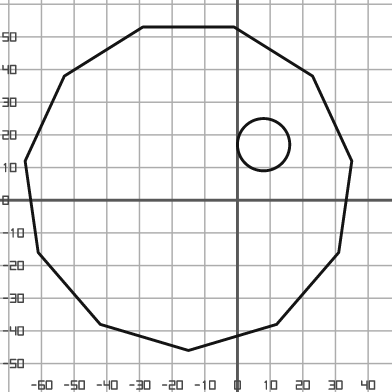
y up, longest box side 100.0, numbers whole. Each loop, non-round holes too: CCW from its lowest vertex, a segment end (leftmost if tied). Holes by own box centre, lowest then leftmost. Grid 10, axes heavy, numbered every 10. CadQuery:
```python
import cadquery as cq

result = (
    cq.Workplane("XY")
    .moveTo(-15.0, -46.0)
    .lineTo(12.0, -38.0)
    .lineTo(31.0, -16.0)
    .lineTo(35.0, 12.0)
    .lineTo(23.0, 38.0)
    .lineTo(-1.0, 53.0)
    .lineTo(-29.0, 53.0)
    .lineTo(-53.0, 38.0)
    .lineTo(-65.0, 12.0)
    .lineTo(-61.0, -16.0)
    .lineTo(-42.0, -38.0)
    .close()
    .moveTo(8.0, 17.0)
    .circle(8.0)
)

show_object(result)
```